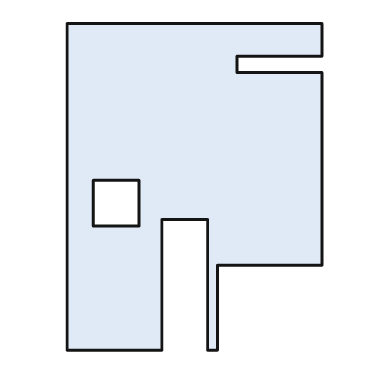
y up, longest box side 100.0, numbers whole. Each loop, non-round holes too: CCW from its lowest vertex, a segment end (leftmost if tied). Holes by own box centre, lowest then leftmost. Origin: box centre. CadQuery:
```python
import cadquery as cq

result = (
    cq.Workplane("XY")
    .moveTo(-39.0, -50.0)
    .lineTo(-10.0, -50.0)
    .lineTo(-10.0, -10.0)
    .lineTo(4.0, -10.0)
    .lineTo(4.0, -50.0)
    .lineTo(7.0, -50.0)
    .lineTo(7.0, -24.0)
    .lineTo(39.0, -24.0)
    .lineTo(39.0, 35.0)
    .lineTo(13.0, 35.0)
    .lineTo(13.0, 40.0)
    .lineTo(39.0, 40.0)
    .lineTo(39.0, 50.0)
    .lineTo(-39.0, 50.0)
    .close()
    .moveTo(-31.0, -12.0)
    .lineTo(-17.0, -12.0)
    .lineTo(-17.0, 2.0)
    .lineTo(-31.0, 2.0)
    .close()
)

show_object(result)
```